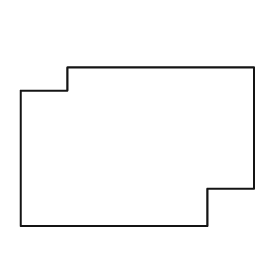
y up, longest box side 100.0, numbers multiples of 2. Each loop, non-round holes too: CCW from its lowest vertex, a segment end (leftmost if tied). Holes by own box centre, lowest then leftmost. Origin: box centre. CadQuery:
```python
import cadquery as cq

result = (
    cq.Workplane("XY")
    .moveTo(-50.0, -34.0)
    .lineTo(30.0, -34.0)
    .lineTo(30.0, -18.0)
    .lineTo(50.0, -18.0)
    .lineTo(50.0, 34.0)
    .lineTo(-30.0, 34.0)
    .lineTo(-30.0, 24.0)
    .lineTo(-50.0, 24.0)
    .close()
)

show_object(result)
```